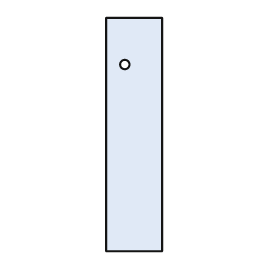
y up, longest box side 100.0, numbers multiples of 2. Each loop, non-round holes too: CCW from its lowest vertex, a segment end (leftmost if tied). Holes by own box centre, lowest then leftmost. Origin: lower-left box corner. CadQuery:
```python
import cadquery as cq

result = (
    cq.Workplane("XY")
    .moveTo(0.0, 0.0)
    .lineTo(24.0, 0.0)
    .lineTo(24.0, 100.0)
    .lineTo(0.0, 100.0)
    .close()
    .moveTo(8.0, 80.0)
    .circle(2.0)
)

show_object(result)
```